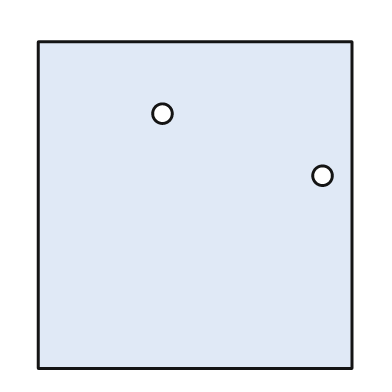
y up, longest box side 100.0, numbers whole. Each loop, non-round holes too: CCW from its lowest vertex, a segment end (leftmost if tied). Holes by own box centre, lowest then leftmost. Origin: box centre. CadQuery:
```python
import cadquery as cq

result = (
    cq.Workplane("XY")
    .moveTo(-48.0, -50.0)
    .lineTo(48.0, -50.0)
    .lineTo(48.0, 50.0)
    .lineTo(-48.0, 50.0)
    .close()
    .moveTo(39.0, 9.0)
    .circle(3.0)
    .moveTo(-10.0, 28.0)
    .circle(3.0)
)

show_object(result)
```